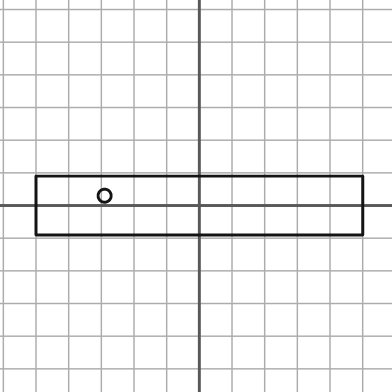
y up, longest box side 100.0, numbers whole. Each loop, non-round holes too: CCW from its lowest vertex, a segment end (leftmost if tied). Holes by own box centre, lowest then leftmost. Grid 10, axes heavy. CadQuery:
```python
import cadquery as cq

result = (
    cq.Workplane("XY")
    .moveTo(-50.0, -9.0)
    .lineTo(50.0, -9.0)
    .lineTo(50.0, 9.0)
    .lineTo(-50.0, 9.0)
    .close()
    .moveTo(-29.0, 3.0)
    .circle(2.0)
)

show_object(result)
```